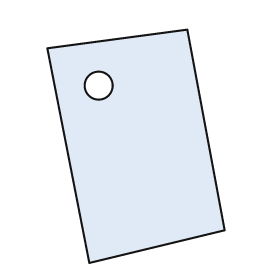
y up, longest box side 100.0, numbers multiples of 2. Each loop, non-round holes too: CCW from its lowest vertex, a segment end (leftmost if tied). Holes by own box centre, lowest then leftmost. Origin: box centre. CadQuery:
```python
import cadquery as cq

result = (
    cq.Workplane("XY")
    .moveTo(-20.0, -50.0)
    .lineTo(38.0, -36.0)
    .lineTo(22.0, 50.0)
    .lineTo(-38.0, 42.0)
    .close()
    .moveTo(-16.0, 26.0)
    .circle(6.0)
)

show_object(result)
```